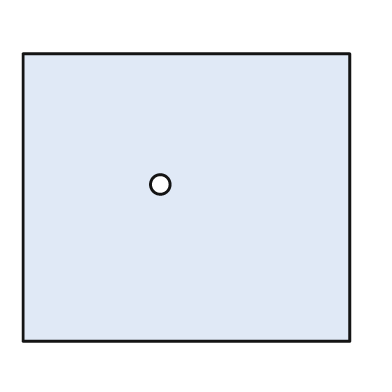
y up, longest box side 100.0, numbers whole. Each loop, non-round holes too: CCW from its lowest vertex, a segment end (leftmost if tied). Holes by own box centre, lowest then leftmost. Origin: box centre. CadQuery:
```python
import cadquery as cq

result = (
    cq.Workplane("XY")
    .moveTo(-50.0, -44.0)
    .lineTo(50.0, -44.0)
    .lineTo(50.0, 44.0)
    .lineTo(-50.0, 44.0)
    .close()
    .moveTo(-8.0, 4.0)
    .circle(3.0)
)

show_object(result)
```